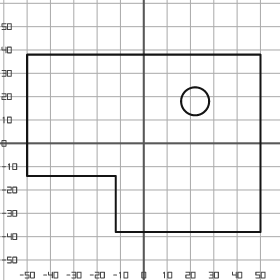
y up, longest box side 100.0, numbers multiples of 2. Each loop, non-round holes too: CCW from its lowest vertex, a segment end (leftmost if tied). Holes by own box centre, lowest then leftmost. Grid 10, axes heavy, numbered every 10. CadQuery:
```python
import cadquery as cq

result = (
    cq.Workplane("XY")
    .moveTo(-12.0, -38.0)
    .lineTo(50.0, -38.0)
    .lineTo(50.0, 38.0)
    .lineTo(-50.0, 38.0)
    .lineTo(-50.0, -14.0)
    .lineTo(-12.0, -14.0)
    .close()
    .moveTo(22.0, 18.0)
    .circle(6.0)
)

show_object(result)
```